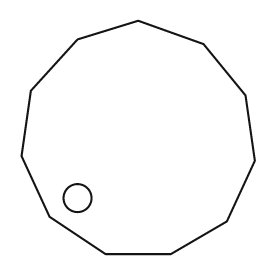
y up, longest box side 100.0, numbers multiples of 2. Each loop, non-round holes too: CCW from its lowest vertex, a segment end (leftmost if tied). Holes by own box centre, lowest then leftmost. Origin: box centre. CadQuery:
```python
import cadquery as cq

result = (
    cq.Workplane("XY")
    .moveTo(-14.0, -50.0)
    .lineTo(14.0, -50.0)
    .lineTo(38.0, -36.0)
    .lineTo(50.0, -10.0)
    .lineTo(46.0, 18.0)
    .lineTo(28.0, 40.0)
    .lineTo(0.0, 50.0)
    .lineTo(-26.0, 42.0)
    .lineTo(-46.0, 20.0)
    .lineTo(-50.0, -8.0)
    .lineTo(-38.0, -34.0)
    .close()
    .moveTo(-26.0, -26.0)
    .circle(6.0)
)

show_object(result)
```